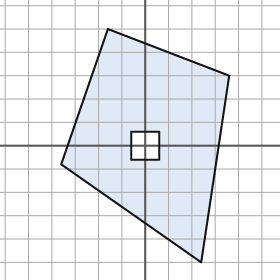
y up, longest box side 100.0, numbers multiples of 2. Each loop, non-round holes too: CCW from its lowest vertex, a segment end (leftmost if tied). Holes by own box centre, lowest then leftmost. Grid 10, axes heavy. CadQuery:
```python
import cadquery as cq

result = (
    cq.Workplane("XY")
    .moveTo(24.0, -50.0)
    .lineTo(36.0, 30.0)
    .lineTo(-16.0, 50.0)
    .lineTo(-36.0, -8.0)
    .close()
    .moveTo(-6.0, -6.0)
    .lineTo(6.0, -6.0)
    .lineTo(6.0, 6.0)
    .lineTo(-6.0, 6.0)
    .close()
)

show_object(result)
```